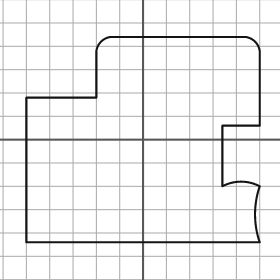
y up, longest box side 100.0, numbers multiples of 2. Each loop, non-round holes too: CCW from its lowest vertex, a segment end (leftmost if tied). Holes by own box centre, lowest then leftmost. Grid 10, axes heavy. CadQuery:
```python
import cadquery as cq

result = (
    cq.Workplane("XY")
    .moveTo(-50.0, -44.0)
    .lineTo(50.0, -44.0)
    .threePointArc((48.0, -32.0), (50.0, -20.0))
    .threePointArc((42.0, -18.0), (34.0, -20.0))
    .lineTo(34.0, 6.0)
    .lineTo(50.0, 6.0)
    .lineTo(50.0, 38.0)
    .threePointArc((48.0, 42.0), (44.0, 44.0))
    .lineTo(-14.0, 44.0)
    .threePointArc((-18.0, 42.0), (-20.0, 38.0))
    .lineTo(-20.0, 18.0)
    .lineTo(-50.0, 18.0)
    .close()
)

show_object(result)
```